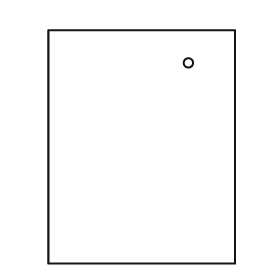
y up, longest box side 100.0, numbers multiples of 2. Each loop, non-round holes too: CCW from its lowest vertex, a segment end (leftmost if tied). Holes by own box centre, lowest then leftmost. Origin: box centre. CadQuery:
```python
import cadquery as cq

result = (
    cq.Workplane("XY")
    .moveTo(-40.0, -50.0)
    .lineTo(40.0, -50.0)
    .lineTo(40.0, 50.0)
    .lineTo(-40.0, 50.0)
    .close()
    .moveTo(20.0, 36.0)
    .circle(2.0)
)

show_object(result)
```